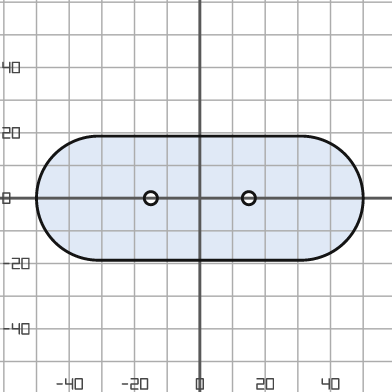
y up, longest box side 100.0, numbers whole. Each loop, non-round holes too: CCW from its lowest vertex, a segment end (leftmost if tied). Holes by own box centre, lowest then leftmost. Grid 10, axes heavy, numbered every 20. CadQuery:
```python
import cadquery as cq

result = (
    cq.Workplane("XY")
    .moveTo(-31.0, -19.0)
    .lineTo(31.0, -19.0)
    .threePointArc((50.0, 0.0), (31.0, 19.0))
    .lineTo(-31.0, 19.0)
    .threePointArc((-50.0, 0.0), (-31.0, -19.0))
    .close()
    .moveTo(-15.0, 0.0)
    .circle(2.0)
    .moveTo(15.0, 0.0)
    .circle(2.0)
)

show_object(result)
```